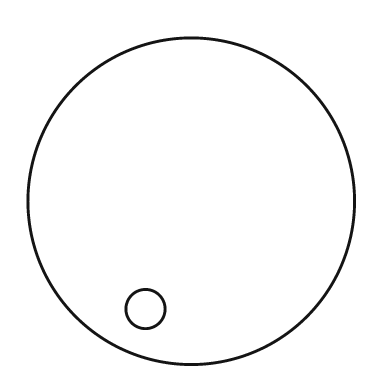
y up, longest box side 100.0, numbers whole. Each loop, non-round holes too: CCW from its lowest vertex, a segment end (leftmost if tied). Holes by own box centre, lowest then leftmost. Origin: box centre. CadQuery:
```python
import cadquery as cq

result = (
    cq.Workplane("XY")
    .moveTo(0.0, 0.0)
    .circle(50.0)
    .moveTo(-14.0, -33.0)
    .circle(6.0)
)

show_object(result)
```